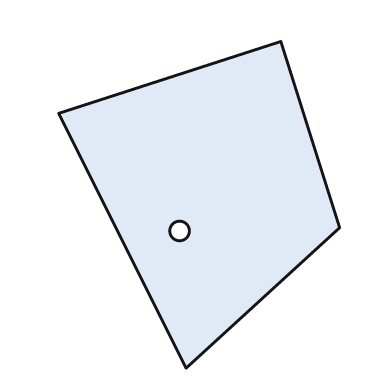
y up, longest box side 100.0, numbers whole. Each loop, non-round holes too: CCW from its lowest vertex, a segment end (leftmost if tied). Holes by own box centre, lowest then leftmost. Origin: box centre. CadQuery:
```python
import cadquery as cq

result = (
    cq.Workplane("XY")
    .moveTo(-4.0, -50.0)
    .lineTo(43.0, -7.0)
    .lineTo(25.0, 50.0)
    .lineTo(-43.0, 28.0)
    .close()
    .moveTo(-6.0, -8.0)
    .circle(3.0)
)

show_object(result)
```